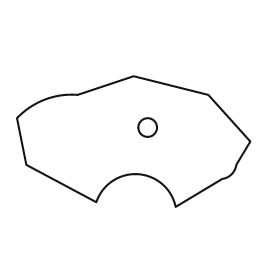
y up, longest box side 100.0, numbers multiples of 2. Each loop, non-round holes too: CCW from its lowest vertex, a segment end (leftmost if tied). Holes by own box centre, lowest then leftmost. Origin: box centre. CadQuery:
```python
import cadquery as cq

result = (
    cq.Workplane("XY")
    .moveTo(18.0, -28.0)
    .lineTo(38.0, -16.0)
    .threePointArc((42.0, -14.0), (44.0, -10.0))
    .lineTo(50.0, 0.0)
    .lineTo(32.0, 20.0)
    .lineTo(0.0, 28.0)
    .lineTo(-24.0, 20.0)
    .threePointArc((-38.0, 18.0), (-50.0, 10.0))
    .lineTo(-46.0, -10.0)
    .lineTo(-16.0, -26.0)
    .threePointArc((2.0, -14.0), (18.0, -28.0))
    .close()
    .moveTo(6.0, 6.0)
    .circle(4.0)
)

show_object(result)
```